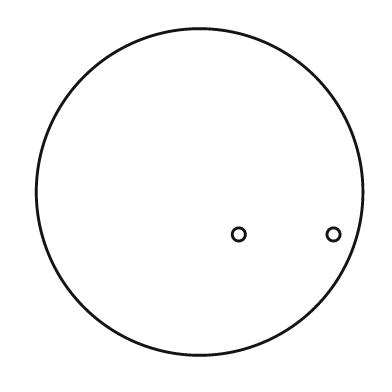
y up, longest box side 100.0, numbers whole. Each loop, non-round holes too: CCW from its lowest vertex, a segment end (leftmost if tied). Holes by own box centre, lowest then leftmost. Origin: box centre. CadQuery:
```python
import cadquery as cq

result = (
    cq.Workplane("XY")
    .moveTo(0.0, 0.0)
    .circle(50.0)
    .moveTo(12.0, -13.0)
    .circle(2.0)
    .moveTo(41.0, -13.0)
    .circle(2.0)
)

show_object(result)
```